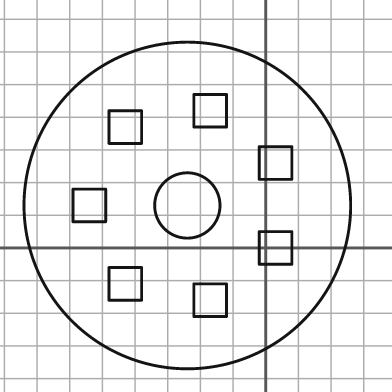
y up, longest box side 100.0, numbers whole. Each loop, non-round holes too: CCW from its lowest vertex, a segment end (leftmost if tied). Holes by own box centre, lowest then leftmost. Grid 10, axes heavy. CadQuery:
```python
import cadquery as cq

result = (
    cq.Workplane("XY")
    .moveTo(-24.0, 13.0)
    .circle(50.0)
    .moveTo(-22.0, -21.0)
    .lineTo(-12.0, -21.0)
    .lineTo(-12.0, -11.0)
    .lineTo(-22.0, -11.0)
    .close()
    .moveTo(-48.0, -16.0)
    .lineTo(-38.0, -16.0)
    .lineTo(-38.0, -6.0)
    .lineTo(-48.0, -6.0)
    .close()
    .moveTo(-2.0, -5.0)
    .lineTo(8.0, -5.0)
    .lineTo(8.0, 5.0)
    .lineTo(-2.0, 5.0)
    .close()
    .moveTo(-59.0, 8.0)
    .lineTo(-49.0, 8.0)
    .lineTo(-49.0, 18.0)
    .lineTo(-59.0, 18.0)
    .close()
    .moveTo(-24.0, 13.0)
    .circle(10.0)
    .moveTo(-2.0, 21.0)
    .lineTo(8.0, 21.0)
    .lineTo(8.0, 31.0)
    .lineTo(-2.0, 31.0)
    .close()
    .moveTo(-48.0, 32.0)
    .lineTo(-38.0, 32.0)
    .lineTo(-38.0, 42.0)
    .lineTo(-48.0, 42.0)
    .close()
    .moveTo(-22.0, 37.0)
    .lineTo(-12.0, 37.0)
    .lineTo(-12.0, 47.0)
    .lineTo(-22.0, 47.0)
    .close()
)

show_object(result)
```